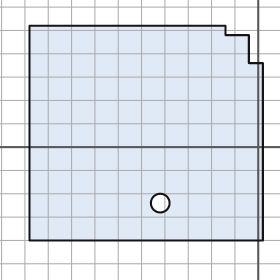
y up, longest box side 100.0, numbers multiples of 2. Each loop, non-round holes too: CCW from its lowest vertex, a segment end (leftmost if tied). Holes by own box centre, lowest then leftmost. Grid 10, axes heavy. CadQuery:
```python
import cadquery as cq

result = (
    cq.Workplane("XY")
    .moveTo(-98.0, -40.0)
    .lineTo(2.0, -40.0)
    .lineTo(2.0, 36.0)
    .lineTo(-4.0, 36.0)
    .lineTo(-4.0, 48.0)
    .lineTo(-14.0, 48.0)
    .lineTo(-14.0, 52.0)
    .lineTo(-98.0, 52.0)
    .close()
    .moveTo(-42.0, -24.0)
    .circle(4.0)
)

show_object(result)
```